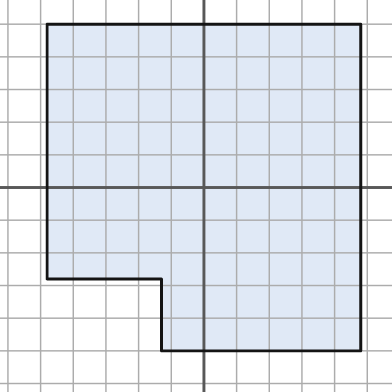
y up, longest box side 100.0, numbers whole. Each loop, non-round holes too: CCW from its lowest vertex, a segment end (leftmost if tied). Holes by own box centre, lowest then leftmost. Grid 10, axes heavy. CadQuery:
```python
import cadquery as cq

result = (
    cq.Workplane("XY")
    .moveTo(-13.0, -50.0)
    .lineTo(48.0, -50.0)
    .lineTo(48.0, 50.0)
    .lineTo(-48.0, 50.0)
    .lineTo(-48.0, -28.0)
    .lineTo(-13.0, -28.0)
    .close()
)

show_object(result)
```